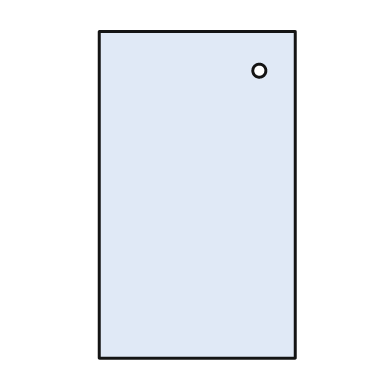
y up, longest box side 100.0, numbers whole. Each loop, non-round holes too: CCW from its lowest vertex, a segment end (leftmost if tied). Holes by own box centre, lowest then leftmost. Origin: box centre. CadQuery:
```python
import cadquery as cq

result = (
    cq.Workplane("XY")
    .moveTo(-30.0, -50.0)
    .lineTo(30.0, -50.0)
    .lineTo(30.0, 50.0)
    .lineTo(-30.0, 50.0)
    .close()
    .moveTo(19.0, 38.0)
    .circle(2.0)
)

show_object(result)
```